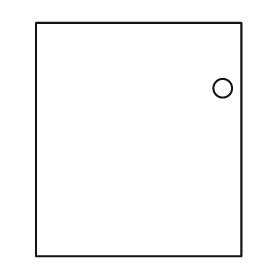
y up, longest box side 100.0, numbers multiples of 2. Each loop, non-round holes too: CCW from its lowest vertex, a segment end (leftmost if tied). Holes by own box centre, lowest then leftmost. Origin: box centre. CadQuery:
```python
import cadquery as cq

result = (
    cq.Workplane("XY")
    .moveTo(-44.0, -50.0)
    .lineTo(44.0, -50.0)
    .lineTo(44.0, 50.0)
    .lineTo(-44.0, 50.0)
    .close()
    .moveTo(36.0, 22.0)
    .circle(4.0)
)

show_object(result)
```